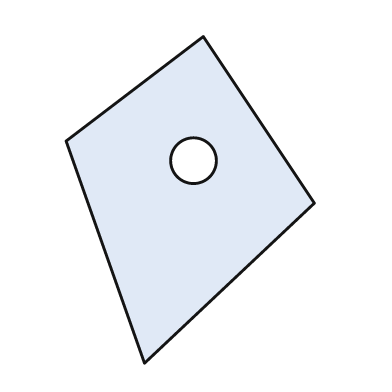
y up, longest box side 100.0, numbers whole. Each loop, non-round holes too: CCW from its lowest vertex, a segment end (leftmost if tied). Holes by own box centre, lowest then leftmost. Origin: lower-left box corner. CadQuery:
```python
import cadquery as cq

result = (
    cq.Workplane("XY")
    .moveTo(24.0, 0.0)
    .lineTo(76.0, 49.0)
    .lineTo(42.0, 100.0)
    .lineTo(0.0, 68.0)
    .close()
    .moveTo(39.0, 62.0)
    .circle(7.0)
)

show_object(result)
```